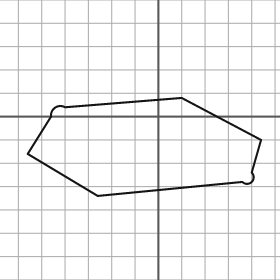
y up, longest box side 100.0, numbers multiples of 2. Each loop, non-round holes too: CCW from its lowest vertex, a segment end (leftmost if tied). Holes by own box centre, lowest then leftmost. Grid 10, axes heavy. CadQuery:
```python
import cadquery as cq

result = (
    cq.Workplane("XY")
    .moveTo(-26.0, -34.0)
    .lineTo(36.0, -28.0)
    .threePointArc((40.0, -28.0), (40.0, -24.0))
    .lineTo(44.0, -10.0)
    .lineTo(10.0, 8.0)
    .lineTo(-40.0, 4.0)
    .threePointArc((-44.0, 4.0), (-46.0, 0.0))
    .lineTo(-56.0, -16.0)
    .close()
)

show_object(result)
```